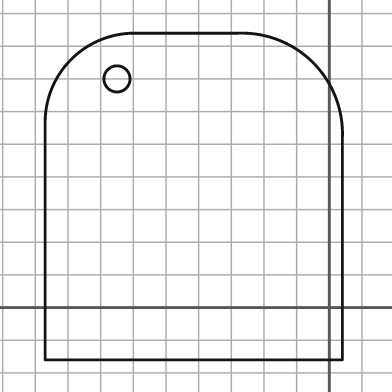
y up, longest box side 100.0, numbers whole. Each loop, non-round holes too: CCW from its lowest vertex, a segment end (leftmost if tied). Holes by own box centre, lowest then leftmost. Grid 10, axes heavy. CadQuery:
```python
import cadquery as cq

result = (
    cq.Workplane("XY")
    .moveTo(-87.0, -16.0)
    .lineTo(4.0, -16.0)
    .lineTo(4.0, 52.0)
    .threePointArc((-5.0, 75.0), (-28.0, 84.0))
    .lineTo(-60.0, 84.0)
    .threePointArc((-79.0, 76.0), (-87.0, 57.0))
    .close()
    .moveTo(-65.0, 70.0)
    .circle(4.0)
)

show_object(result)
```